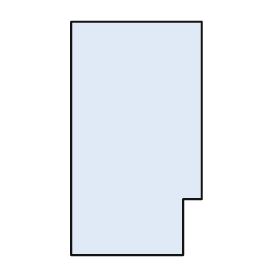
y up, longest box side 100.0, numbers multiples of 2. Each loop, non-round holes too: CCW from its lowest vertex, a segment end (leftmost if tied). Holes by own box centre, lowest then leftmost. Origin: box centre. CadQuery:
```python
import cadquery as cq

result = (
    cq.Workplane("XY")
    .moveTo(-28.0, -50.0)
    .lineTo(20.0, -50.0)
    .lineTo(20.0, -26.0)
    .lineTo(28.0, -26.0)
    .lineTo(28.0, 50.0)
    .lineTo(-28.0, 50.0)
    .close()
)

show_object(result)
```